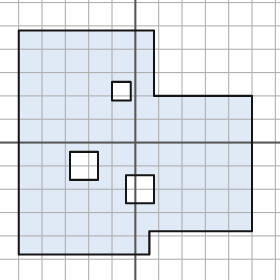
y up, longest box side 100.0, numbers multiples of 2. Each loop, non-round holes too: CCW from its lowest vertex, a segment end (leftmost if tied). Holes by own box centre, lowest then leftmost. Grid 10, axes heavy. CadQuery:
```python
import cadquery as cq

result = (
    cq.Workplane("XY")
    .moveTo(-50.0, -48.0)
    .lineTo(6.0, -48.0)
    .lineTo(6.0, -38.0)
    .lineTo(50.0, -38.0)
    .lineTo(50.0, 20.0)
    .lineTo(8.0, 20.0)
    .lineTo(8.0, 48.0)
    .lineTo(-50.0, 48.0)
    .close()
    .moveTo(-4.0, -26.0)
    .lineTo(8.0, -26.0)
    .lineTo(8.0, -14.0)
    .lineTo(-4.0, -14.0)
    .close()
    .moveTo(-28.0, -16.0)
    .lineTo(-16.0, -16.0)
    .lineTo(-16.0, -4.0)
    .lineTo(-28.0, -4.0)
    .close()
    .moveTo(-10.0, 18.0)
    .lineTo(-2.0, 18.0)
    .lineTo(-2.0, 26.0)
    .lineTo(-10.0, 26.0)
    .close()
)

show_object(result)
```